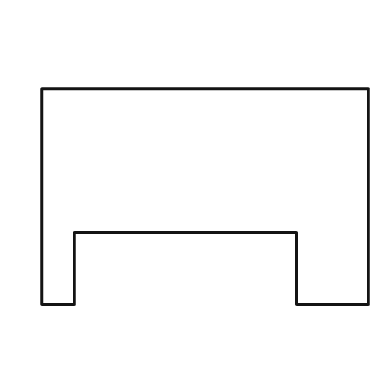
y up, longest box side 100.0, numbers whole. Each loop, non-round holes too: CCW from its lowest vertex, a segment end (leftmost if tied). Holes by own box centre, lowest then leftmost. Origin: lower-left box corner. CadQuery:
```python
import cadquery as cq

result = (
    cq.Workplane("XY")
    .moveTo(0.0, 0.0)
    .lineTo(10.0, 0.0)
    .lineTo(10.0, 22.0)
    .lineTo(78.0, 22.0)
    .lineTo(78.0, 0.0)
    .lineTo(100.0, 0.0)
    .lineTo(100.0, 66.0)
    .lineTo(0.0, 66.0)
    .close()
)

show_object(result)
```